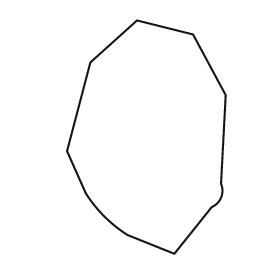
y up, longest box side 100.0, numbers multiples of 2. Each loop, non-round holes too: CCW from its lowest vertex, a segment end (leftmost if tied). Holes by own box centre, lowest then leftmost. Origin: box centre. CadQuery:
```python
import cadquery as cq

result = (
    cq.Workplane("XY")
    .moveTo(12.0, -50.0)
    .lineTo(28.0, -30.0)
    .threePointArc((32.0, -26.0), (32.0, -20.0))
    .lineTo(34.0, 18.0)
    .lineTo(20.0, 44.0)
    .lineTo(-4.0, 50.0)
    .lineTo(-24.0, 32.0)
    .lineTo(-34.0, -6.0)
    .lineTo(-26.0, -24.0)
    .threePointArc((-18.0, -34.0), (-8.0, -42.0))
    .close()
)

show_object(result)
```